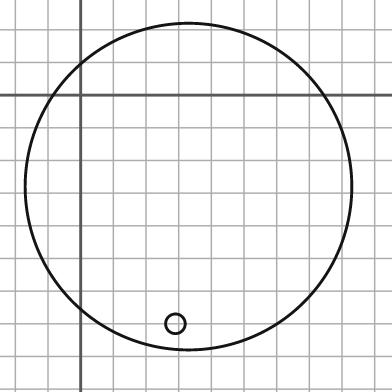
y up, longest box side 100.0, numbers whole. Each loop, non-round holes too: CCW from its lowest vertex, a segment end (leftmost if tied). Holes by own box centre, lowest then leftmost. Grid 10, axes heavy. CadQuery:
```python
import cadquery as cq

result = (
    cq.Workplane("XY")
    .moveTo(33.0, -28.0)
    .circle(50.0)
    .moveTo(29.0, -70.0)
    .circle(3.0)
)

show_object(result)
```